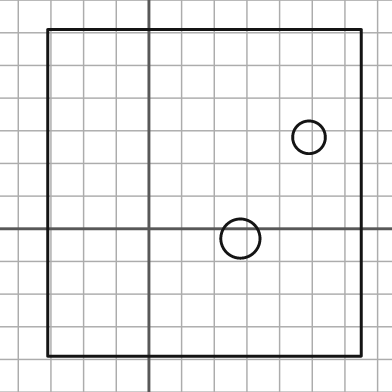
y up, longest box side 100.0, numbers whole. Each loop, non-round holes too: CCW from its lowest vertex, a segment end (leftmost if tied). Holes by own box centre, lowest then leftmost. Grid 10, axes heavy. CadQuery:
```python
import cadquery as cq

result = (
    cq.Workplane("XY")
    .moveTo(-31.0, -39.0)
    .lineTo(65.0, -39.0)
    .lineTo(65.0, 61.0)
    .lineTo(-31.0, 61.0)
    .close()
    .moveTo(28.0, -3.0)
    .circle(6.0)
    .moveTo(49.0, 28.0)
    .circle(5.0)
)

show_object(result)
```